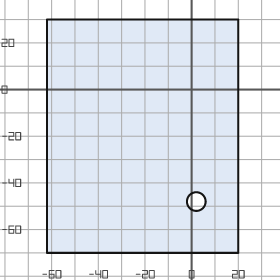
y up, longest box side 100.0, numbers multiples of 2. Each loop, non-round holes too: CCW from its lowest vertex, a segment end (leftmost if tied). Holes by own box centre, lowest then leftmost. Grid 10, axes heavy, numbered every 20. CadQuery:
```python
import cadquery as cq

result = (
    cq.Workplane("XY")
    .moveTo(-62.0, -70.0)
    .lineTo(20.0, -70.0)
    .lineTo(20.0, 30.0)
    .lineTo(-62.0, 30.0)
    .close()
    .moveTo(2.0, -48.0)
    .circle(4.0)
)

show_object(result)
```